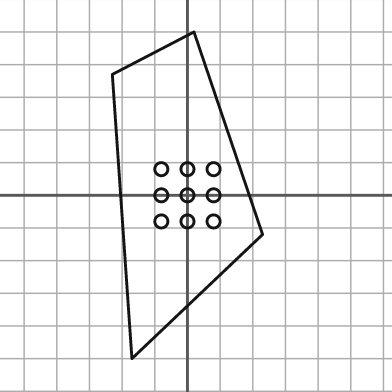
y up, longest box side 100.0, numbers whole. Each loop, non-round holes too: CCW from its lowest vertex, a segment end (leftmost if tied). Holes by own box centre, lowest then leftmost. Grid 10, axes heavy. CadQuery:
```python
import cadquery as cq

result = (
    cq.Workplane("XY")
    .moveTo(-17.0, -50.0)
    .lineTo(23.0, -12.0)
    .lineTo(2.0, 50.0)
    .lineTo(-23.0, 37.0)
    .close()
    .moveTo(-8.0, -8.0)
    .circle(2.0)
    .moveTo(0.0, -8.0)
    .circle(2.0)
    .moveTo(8.0, -8.0)
    .circle(2.0)
    .moveTo(-8.0, 0.0)
    .circle(2.0)
    .moveTo(0.0, 0.0)
    .circle(2.0)
    .moveTo(8.0, 0.0)
    .circle(2.0)
    .moveTo(-8.0, 8.0)
    .circle(2.0)
    .moveTo(0.0, 8.0)
    .circle(2.0)
    .moveTo(8.0, 8.0)
    .circle(2.0)
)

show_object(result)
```